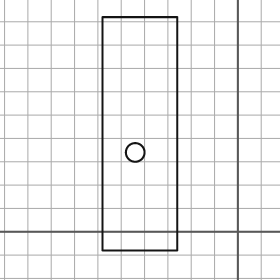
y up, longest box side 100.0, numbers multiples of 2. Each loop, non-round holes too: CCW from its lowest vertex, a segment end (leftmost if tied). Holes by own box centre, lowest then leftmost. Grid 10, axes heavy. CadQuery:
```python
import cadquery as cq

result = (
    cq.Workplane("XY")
    .moveTo(-58.0, -8.0)
    .lineTo(-26.0, -8.0)
    .lineTo(-26.0, 92.0)
    .lineTo(-58.0, 92.0)
    .close()
    .moveTo(-44.0, 34.0)
    .circle(4.0)
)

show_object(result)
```